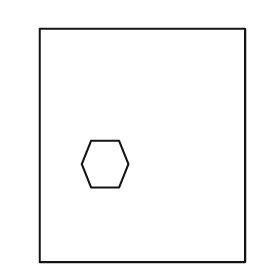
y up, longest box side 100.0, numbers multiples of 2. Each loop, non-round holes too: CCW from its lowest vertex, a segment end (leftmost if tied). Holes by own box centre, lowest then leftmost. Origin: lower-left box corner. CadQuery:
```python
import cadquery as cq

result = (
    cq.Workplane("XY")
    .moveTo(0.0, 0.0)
    .lineTo(88.0, 0.0)
    .lineTo(88.0, 100.0)
    .lineTo(0.0, 100.0)
    .close()
    .moveTo(22.0, 32.0)
    .lineTo(34.0, 32.0)
    .lineTo(38.0, 42.0)
    .lineTo(34.0, 52.0)
    .lineTo(22.0, 52.0)
    .lineTo(18.0, 42.0)
    .close()
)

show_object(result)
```